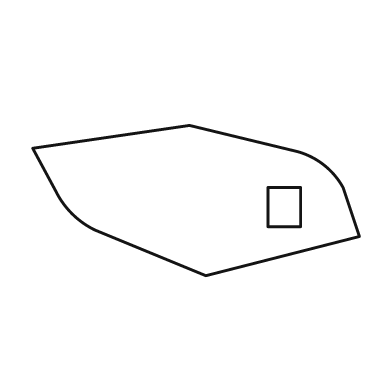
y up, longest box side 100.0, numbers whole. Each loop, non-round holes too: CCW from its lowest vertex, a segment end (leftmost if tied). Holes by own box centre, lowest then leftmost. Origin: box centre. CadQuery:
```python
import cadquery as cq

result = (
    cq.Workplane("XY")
    .moveTo(3.0, -23.0)
    .lineTo(50.0, -11.0)
    .lineTo(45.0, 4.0)
    .threePointArc((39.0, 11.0), (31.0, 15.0))
    .lineTo(-2.0, 23.0)
    .lineTo(-50.0, 16.0)
    .lineTo(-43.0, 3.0)
    .threePointArc((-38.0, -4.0), (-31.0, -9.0))
    .close()
    .moveTo(22.0, -8.0)
    .lineTo(32.0, -8.0)
    .lineTo(32.0, 4.0)
    .lineTo(22.0, 4.0)
    .close()
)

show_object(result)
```